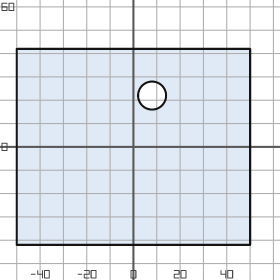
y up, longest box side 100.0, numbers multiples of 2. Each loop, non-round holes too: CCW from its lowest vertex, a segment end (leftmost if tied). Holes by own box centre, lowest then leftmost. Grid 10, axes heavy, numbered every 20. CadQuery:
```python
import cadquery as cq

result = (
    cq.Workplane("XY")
    .moveTo(-50.0, -42.0)
    .lineTo(50.0, -42.0)
    .lineTo(50.0, 42.0)
    .lineTo(-50.0, 42.0)
    .close()
    .moveTo(8.0, 22.0)
    .circle(6.0)
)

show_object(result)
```